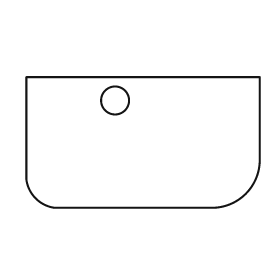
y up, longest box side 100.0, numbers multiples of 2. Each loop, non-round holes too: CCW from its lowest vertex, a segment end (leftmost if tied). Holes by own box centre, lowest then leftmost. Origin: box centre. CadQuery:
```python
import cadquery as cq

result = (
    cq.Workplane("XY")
    .moveTo(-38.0, -28.0)
    .lineTo(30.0, -28.0)
    .threePointArc((44.0, -22.0), (50.0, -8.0))
    .lineTo(50.0, 28.0)
    .lineTo(-50.0, 28.0)
    .lineTo(-50.0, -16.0)
    .threePointArc((-46.0, -24.0), (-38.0, -28.0))
    .close()
    .moveTo(-12.0, 18.0)
    .circle(6.0)
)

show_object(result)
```